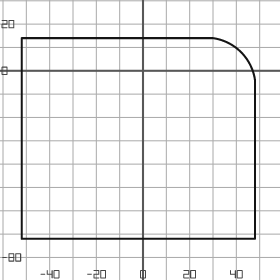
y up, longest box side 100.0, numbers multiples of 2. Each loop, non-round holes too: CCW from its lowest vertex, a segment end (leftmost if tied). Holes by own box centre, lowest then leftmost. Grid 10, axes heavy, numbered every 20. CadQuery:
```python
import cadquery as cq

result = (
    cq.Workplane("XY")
    .moveTo(-52.0, -72.0)
    .lineTo(48.0, -72.0)
    .lineTo(48.0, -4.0)
    .threePointArc((42.0, 8.0), (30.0, 14.0))
    .lineTo(-52.0, 14.0)
    .close()
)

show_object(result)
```